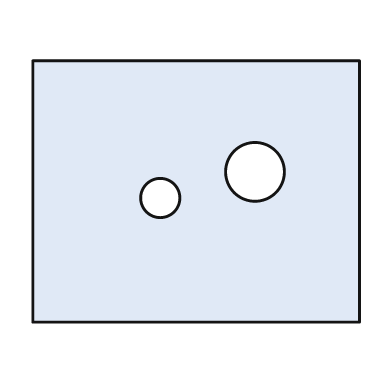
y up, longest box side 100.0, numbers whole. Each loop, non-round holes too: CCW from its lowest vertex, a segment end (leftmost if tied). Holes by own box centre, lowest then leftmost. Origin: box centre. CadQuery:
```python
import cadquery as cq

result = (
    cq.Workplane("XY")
    .moveTo(-50.0, -40.0)
    .lineTo(50.0, -40.0)
    .lineTo(50.0, 40.0)
    .lineTo(-50.0, 40.0)
    .close()
    .moveTo(-11.0, -2.0)
    .circle(6.0)
    .moveTo(18.0, 6.0)
    .circle(9.0)
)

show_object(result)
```